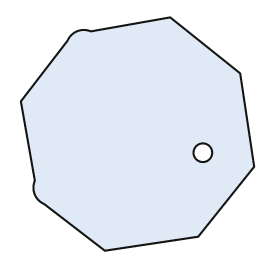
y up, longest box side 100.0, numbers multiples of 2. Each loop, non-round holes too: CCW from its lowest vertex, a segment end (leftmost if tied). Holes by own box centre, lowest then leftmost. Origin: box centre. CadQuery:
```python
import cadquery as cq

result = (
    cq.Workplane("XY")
    .moveTo(-14.0, -50.0)
    .lineTo(26.0, -44.0)
    .lineTo(50.0, -14.0)
    .lineTo(44.0, 26.0)
    .lineTo(14.0, 50.0)
    .lineTo(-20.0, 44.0)
    .threePointArc((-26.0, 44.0), (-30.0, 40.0))
    .lineTo(-50.0, 14.0)
    .lineTo(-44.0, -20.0)
    .threePointArc((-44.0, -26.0), (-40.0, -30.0))
    .close()
    .moveTo(28.0, -8.0)
    .circle(4.0)
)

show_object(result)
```